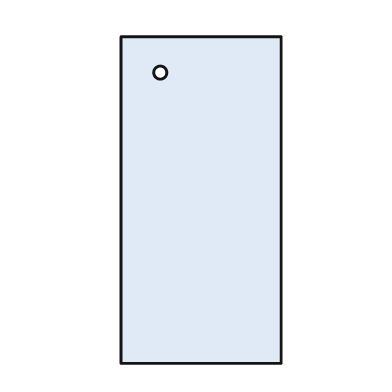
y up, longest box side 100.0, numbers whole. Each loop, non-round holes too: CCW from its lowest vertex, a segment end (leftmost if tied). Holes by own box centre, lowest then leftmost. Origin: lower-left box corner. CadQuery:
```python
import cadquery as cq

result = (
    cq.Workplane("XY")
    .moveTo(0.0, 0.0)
    .lineTo(49.0, 0.0)
    .lineTo(49.0, 100.0)
    .lineTo(0.0, 100.0)
    .close()
    .moveTo(12.0, 89.0)
    .circle(2.0)
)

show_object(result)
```